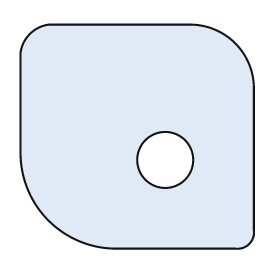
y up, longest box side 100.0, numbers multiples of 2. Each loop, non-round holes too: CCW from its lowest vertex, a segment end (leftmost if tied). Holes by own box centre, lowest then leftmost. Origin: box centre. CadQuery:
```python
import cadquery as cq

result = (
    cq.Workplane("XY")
    .moveTo(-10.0, -48.0)
    .lineTo(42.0, -48.0)
    .threePointArc((48.0, -46.0), (50.0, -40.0))
    .lineTo(50.0, 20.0)
    .threePointArc((42.0, 40.0), (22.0, 48.0))
    .lineTo(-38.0, 48.0)
    .threePointArc((-46.0, 44.0), (-50.0, 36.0))
    .lineTo(-50.0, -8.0)
    .threePointArc((-38.0, -36.0), (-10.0, -48.0))
    .close()
    .moveTo(12.0, -10.0)
    .circle(12.0)
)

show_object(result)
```